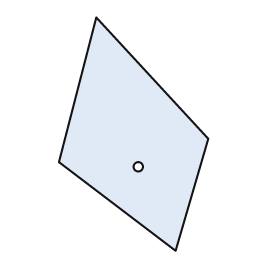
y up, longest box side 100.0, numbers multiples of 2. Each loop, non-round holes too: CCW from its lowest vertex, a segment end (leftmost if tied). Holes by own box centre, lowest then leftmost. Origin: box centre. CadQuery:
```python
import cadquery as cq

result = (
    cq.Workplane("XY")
    .moveTo(18.0, -50.0)
    .lineTo(32.0, -2.0)
    .lineTo(-16.0, 50.0)
    .lineTo(-32.0, -12.0)
    .close()
    .moveTo(2.0, -14.0)
    .circle(2.0)
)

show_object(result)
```